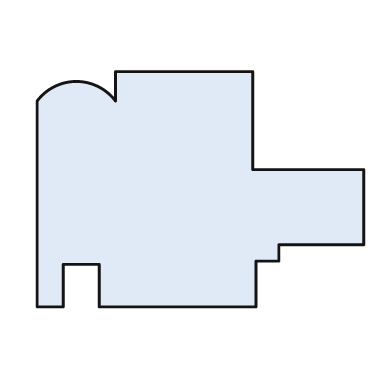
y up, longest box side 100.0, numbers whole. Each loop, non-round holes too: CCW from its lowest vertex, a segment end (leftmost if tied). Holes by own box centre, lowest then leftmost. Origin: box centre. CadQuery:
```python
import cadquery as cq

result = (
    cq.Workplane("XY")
    .moveTo(-50.0, -36.0)
    .lineTo(-42.0, -36.0)
    .lineTo(-42.0, -23.0)
    .lineTo(-31.0, -23.0)
    .lineTo(-31.0, -36.0)
    .lineTo(17.0, -36.0)
    .lineTo(17.0, -22.0)
    .lineTo(24.0, -22.0)
    .lineTo(24.0, -17.0)
    .lineTo(50.0, -17.0)
    .lineTo(50.0, 6.0)
    .lineTo(16.0, 6.0)
    .lineTo(16.0, 36.0)
    .lineTo(-26.0, 36.0)
    .lineTo(-26.0, 27.0)
    .threePointArc((-38.0, 33.0), (-50.0, 27.0))
    .close()
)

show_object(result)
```